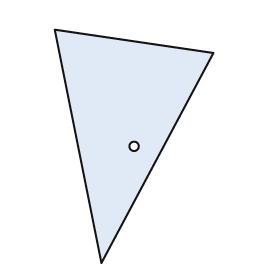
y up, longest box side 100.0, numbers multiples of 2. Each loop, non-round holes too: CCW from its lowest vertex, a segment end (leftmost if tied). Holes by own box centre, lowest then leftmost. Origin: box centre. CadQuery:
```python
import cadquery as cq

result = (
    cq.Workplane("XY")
    .moveTo(-14.0, -50.0)
    .lineTo(34.0, 40.0)
    .lineTo(-34.0, 50.0)
    .close()
    .moveTo(0.0, 0.0)
    .circle(2.0)
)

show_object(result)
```